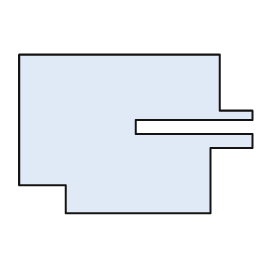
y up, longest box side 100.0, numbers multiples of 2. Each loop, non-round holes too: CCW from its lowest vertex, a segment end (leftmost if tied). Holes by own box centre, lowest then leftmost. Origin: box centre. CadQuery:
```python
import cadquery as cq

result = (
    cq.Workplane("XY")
    .moveTo(-30.0, -34.0)
    .lineTo(32.0, -34.0)
    .lineTo(32.0, -6.0)
    .lineTo(50.0, -6.0)
    .lineTo(50.0, 0.0)
    .lineTo(0.0, 0.0)
    .lineTo(0.0, 6.0)
    .lineTo(50.0, 6.0)
    .lineTo(50.0, 10.0)
    .lineTo(36.0, 10.0)
    .lineTo(36.0, 34.0)
    .lineTo(-50.0, 34.0)
    .lineTo(-50.0, -22.0)
    .lineTo(-30.0, -22.0)
    .close()
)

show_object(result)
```